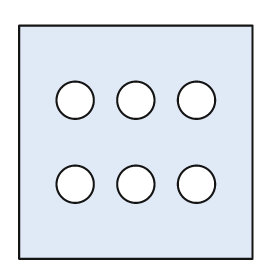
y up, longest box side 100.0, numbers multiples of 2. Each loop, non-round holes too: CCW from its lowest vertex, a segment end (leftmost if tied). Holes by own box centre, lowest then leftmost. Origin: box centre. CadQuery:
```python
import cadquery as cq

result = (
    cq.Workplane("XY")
    .moveTo(-50.0, -50.0)
    .lineTo(50.0, -50.0)
    .lineTo(50.0, 50.0)
    .lineTo(-50.0, 50.0)
    .close()
    .moveTo(-26.0, -18.0)
    .circle(8.0)
    .moveTo(0.0, -18.0)
    .circle(8.0)
    .moveTo(26.0, -18.0)
    .circle(8.0)
    .moveTo(-26.0, 18.0)
    .circle(8.0)
    .moveTo(0.0, 18.0)
    .circle(8.0)
    .moveTo(26.0, 18.0)
    .circle(8.0)
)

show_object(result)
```